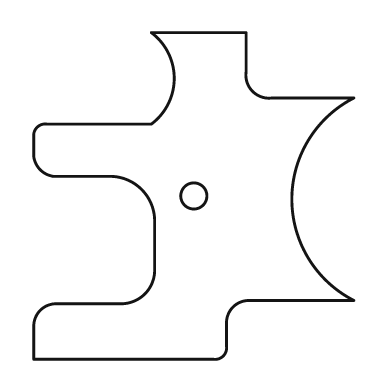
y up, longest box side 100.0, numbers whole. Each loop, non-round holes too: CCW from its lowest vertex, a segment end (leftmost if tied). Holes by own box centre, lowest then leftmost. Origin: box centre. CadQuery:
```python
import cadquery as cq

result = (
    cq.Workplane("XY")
    .moveTo(-49.0, -50.0)
    .lineTo(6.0, -50.0)
    .threePointArc((9.0, -49.0), (10.0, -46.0))
    .lineTo(10.0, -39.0)
    .threePointArc((12.0, -34.0), (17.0, -32.0))
    .lineTo(49.0, -32.0)
    .threePointArc((30.0, -1.0), (49.0, 30.0))
    .lineTo(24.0, 30.0)
    .threePointArc((18.0, 32.0), (16.0, 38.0))
    .lineTo(16.0, 50.0)
    .lineTo(-13.0, 50.0)
    .threePointArc((-6.0, 36.0), (-13.0, 22.0))
    .lineTo(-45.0, 22.0)
    .threePointArc((-48.0, 21.0), (-49.0, 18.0))
    .lineTo(-49.0, 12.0)
    .threePointArc((-47.0, 8.0), (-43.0, 6.0))
    .lineTo(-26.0, 6.0)
    .threePointArc((-16.0, 2.0), (-12.0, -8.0))
    .lineTo(-12.0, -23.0)
    .threePointArc((-15.0, -30.0), (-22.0, -33.0))
    .lineTo(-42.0, -33.0)
    .threePointArc((-47.0, -35.0), (-49.0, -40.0))
    .close()
    .moveTo(0.0, 0.0)
    .circle(4.0)
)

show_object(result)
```